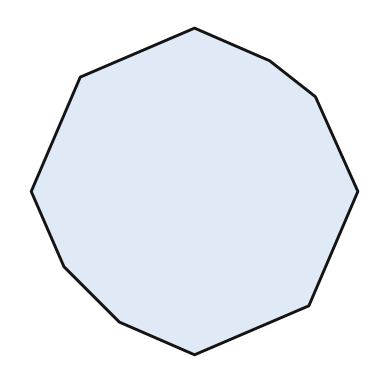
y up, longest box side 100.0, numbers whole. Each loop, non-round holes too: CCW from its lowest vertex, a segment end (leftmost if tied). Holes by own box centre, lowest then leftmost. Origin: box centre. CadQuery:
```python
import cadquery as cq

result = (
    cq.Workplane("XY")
    .moveTo(0.0, -50.0)
    .lineTo(35.0, -35.0)
    .lineTo(50.0, 0.0)
    .lineTo(37.0, 29.0)
    .lineTo(23.0, 40.0)
    .lineTo(0.0, 50.0)
    .lineTo(-35.0, 35.0)
    .lineTo(-50.0, 0.0)
    .lineTo(-40.0, -23.0)
    .lineTo(-23.0, -40.0)
    .close()
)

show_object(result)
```